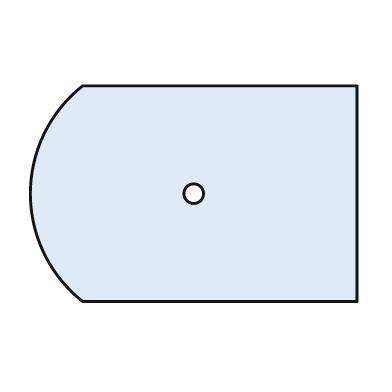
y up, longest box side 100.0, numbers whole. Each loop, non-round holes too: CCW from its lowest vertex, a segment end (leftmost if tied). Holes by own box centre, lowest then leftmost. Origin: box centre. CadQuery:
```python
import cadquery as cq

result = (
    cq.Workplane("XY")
    .moveTo(-34.0, -33.0)
    .lineTo(50.0, -33.0)
    .lineTo(50.0, 33.0)
    .lineTo(-34.0, 33.0)
    .threePointArc((-50.0, 0.0), (-34.0, -33.0))
    .close()
    .moveTo(0.0, 0.0)
    .circle(3.0)
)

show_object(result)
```